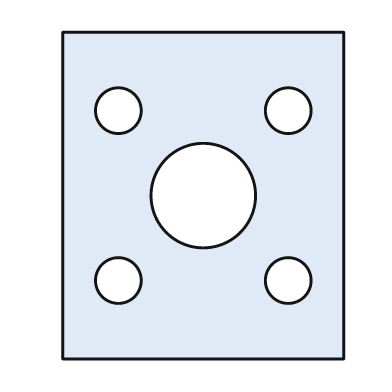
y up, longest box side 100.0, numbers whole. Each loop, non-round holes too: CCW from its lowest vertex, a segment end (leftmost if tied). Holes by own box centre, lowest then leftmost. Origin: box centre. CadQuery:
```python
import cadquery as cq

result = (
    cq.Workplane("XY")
    .moveTo(-43.0, -50.0)
    .lineTo(43.0, -50.0)
    .lineTo(43.0, 50.0)
    .lineTo(-43.0, 50.0)
    .close()
    .moveTo(-26.0, -26.0)
    .circle(7.0)
    .moveTo(26.0, -26.0)
    .circle(7.0)
    .moveTo(0.0, 0.0)
    .circle(16.0)
    .moveTo(-26.0, 26.0)
    .circle(7.0)
    .moveTo(26.0, 26.0)
    .circle(7.0)
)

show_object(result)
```